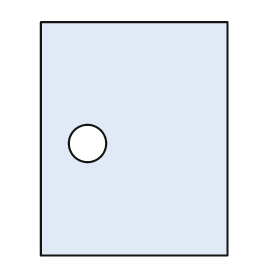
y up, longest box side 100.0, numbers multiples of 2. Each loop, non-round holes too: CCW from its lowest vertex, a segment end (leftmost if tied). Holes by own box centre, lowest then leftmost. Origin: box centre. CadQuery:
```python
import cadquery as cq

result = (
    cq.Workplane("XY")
    .moveTo(-40.0, -50.0)
    .lineTo(40.0, -50.0)
    .lineTo(40.0, 50.0)
    .lineTo(-40.0, 50.0)
    .close()
    .moveTo(-20.0, -2.0)
    .circle(8.0)
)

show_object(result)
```